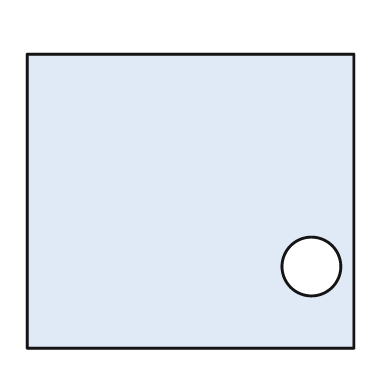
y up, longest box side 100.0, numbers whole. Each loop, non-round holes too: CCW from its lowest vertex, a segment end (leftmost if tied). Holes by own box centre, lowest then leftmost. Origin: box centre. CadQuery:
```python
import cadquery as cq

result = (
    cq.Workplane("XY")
    .moveTo(-50.0, -45.0)
    .lineTo(50.0, -45.0)
    .lineTo(50.0, 45.0)
    .lineTo(-50.0, 45.0)
    .close()
    .moveTo(37.0, -20.0)
    .circle(9.0)
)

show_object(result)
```